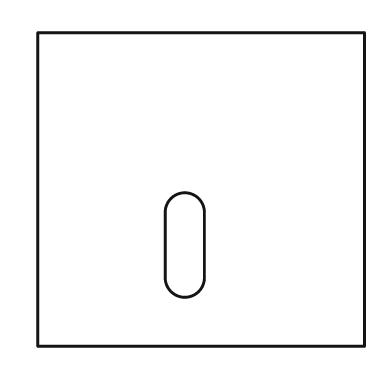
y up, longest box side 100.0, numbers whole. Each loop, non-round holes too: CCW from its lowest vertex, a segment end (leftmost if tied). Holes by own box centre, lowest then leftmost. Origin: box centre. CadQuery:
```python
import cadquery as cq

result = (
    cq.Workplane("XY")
    .moveTo(-50.0, -48.0)
    .lineTo(50.0, -48.0)
    .lineTo(50.0, 48.0)
    .lineTo(-50.0, 48.0)
    .close()
    .moveTo(-11.0, -27.0)
    .threePointArc((-5.0, -33.0), (1.0, -27.0))
    .lineTo(1.0, -7.0)
    .threePointArc((-5.0, -1.0), (-11.0, -7.0))
    .close()
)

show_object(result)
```